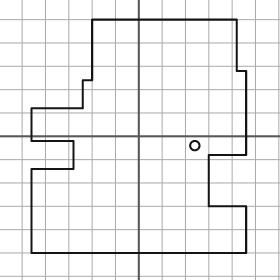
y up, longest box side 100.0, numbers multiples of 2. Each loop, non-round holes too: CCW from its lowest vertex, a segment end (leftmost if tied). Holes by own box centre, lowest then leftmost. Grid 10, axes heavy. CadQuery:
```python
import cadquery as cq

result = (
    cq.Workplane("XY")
    .moveTo(-46.0, -50.0)
    .lineTo(46.0, -50.0)
    .lineTo(46.0, -30.0)
    .lineTo(30.0, -30.0)
    .lineTo(30.0, -8.0)
    .lineTo(46.0, -8.0)
    .lineTo(46.0, 28.0)
    .lineTo(42.0, 28.0)
    .lineTo(42.0, 50.0)
    .lineTo(-20.0, 50.0)
    .lineTo(-20.0, 24.0)
    .lineTo(-24.0, 24.0)
    .lineTo(-24.0, 12.0)
    .lineTo(-46.0, 12.0)
    .lineTo(-46.0, -2.0)
    .lineTo(-28.0, -2.0)
    .lineTo(-28.0, -14.0)
    .lineTo(-46.0, -14.0)
    .close()
    .moveTo(24.0, -4.0)
    .circle(2.0)
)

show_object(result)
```